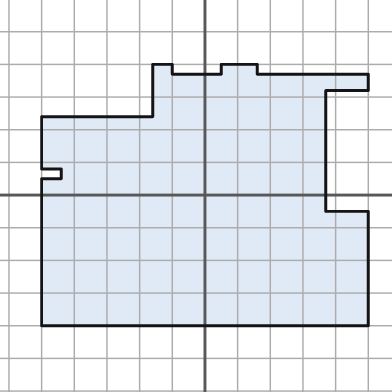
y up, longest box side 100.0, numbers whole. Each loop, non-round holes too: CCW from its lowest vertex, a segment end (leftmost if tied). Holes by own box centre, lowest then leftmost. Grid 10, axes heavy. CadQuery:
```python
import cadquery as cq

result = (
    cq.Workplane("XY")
    .moveTo(-50.0, -40.0)
    .lineTo(50.0, -40.0)
    .lineTo(50.0, -5.0)
    .lineTo(37.0, -5.0)
    .lineTo(37.0, 32.0)
    .lineTo(50.0, 32.0)
    .lineTo(50.0, 37.0)
    .lineTo(16.0, 37.0)
    .lineTo(16.0, 40.0)
    .lineTo(5.0, 40.0)
    .lineTo(5.0, 37.0)
    .lineTo(-10.0, 37.0)
    .lineTo(-10.0, 40.0)
    .lineTo(-16.0, 40.0)
    .lineTo(-16.0, 24.0)
    .lineTo(-50.0, 24.0)
    .lineTo(-50.0, 8.0)
    .lineTo(-44.0, 8.0)
    .lineTo(-44.0, 5.0)
    .lineTo(-50.0, 5.0)
    .close()
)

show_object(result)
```